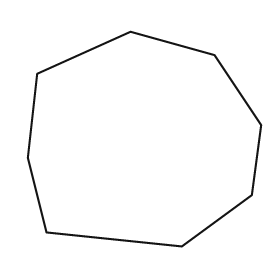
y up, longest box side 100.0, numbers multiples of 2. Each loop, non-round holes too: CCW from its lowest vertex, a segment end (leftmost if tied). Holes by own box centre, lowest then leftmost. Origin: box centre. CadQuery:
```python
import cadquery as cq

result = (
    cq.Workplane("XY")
    .moveTo(16.0, -46.0)
    .lineTo(46.0, -24.0)
    .lineTo(50.0, 6.0)
    .lineTo(30.0, 36.0)
    .lineTo(-6.0, 46.0)
    .lineTo(-46.0, 28.0)
    .lineTo(-50.0, -8.0)
    .lineTo(-42.0, -40.0)
    .close()
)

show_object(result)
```